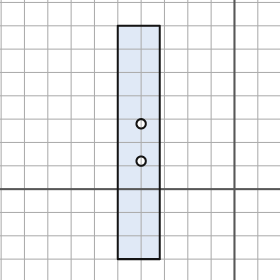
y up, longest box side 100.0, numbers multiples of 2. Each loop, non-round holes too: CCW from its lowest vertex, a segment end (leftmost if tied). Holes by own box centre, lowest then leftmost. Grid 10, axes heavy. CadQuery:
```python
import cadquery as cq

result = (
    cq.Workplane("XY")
    .moveTo(-50.0, -30.0)
    .lineTo(-32.0, -30.0)
    .lineTo(-32.0, 70.0)
    .lineTo(-50.0, 70.0)
    .close()
    .moveTo(-40.0, 12.0)
    .circle(2.0)
    .moveTo(-40.0, 28.0)
    .circle(2.0)
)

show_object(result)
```